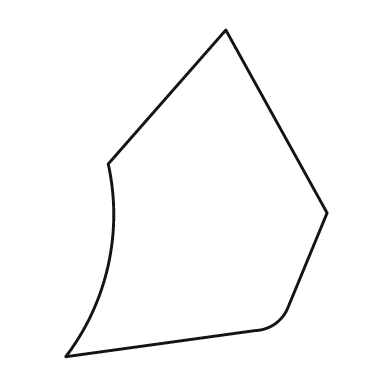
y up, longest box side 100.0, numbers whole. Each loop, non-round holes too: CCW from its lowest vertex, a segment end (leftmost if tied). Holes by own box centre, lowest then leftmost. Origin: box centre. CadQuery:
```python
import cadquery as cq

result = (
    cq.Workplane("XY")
    .moveTo(-40.0, -50.0)
    .lineTo(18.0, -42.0)
    .threePointArc((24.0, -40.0), (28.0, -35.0))
    .lineTo(40.0, -6.0)
    .lineTo(9.0, 50.0)
    .lineTo(-27.0, 9.0)
    .threePointArc((-27.0, -22.0), (-40.0, -50.0))
    .close()
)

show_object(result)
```